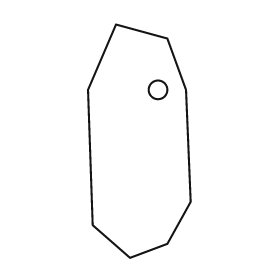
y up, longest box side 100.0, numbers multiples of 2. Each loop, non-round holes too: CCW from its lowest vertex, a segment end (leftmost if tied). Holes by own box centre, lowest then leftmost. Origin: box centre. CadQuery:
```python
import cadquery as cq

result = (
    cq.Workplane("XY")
    .moveTo(-4.0, -50.0)
    .lineTo(12.0, -44.0)
    .lineTo(22.0, -26.0)
    .lineTo(20.0, 22.0)
    .lineTo(12.0, 44.0)
    .lineTo(-10.0, 50.0)
    .lineTo(-22.0, 22.0)
    .lineTo(-20.0, -36.0)
    .close()
    .moveTo(8.0, 22.0)
    .circle(4.0)
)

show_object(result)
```